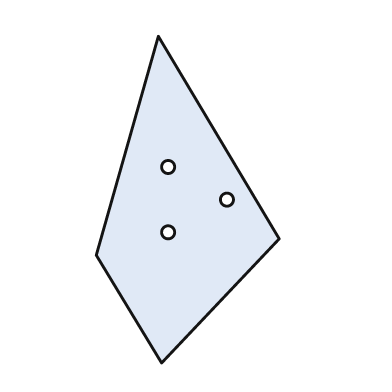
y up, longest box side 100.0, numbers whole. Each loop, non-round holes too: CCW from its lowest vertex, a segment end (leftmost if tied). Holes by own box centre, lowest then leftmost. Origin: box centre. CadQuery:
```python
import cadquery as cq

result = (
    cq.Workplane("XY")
    .moveTo(-8.0, -50.0)
    .lineTo(28.0, -12.0)
    .lineTo(-9.0, 50.0)
    .lineTo(-28.0, -17.0)
    .close()
    .moveTo(-6.0, -10.0)
    .circle(2.0)
    .moveTo(12.0, 0.0)
    .circle(2.0)
    .moveTo(-6.0, 10.0)
    .circle(2.0)
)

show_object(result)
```